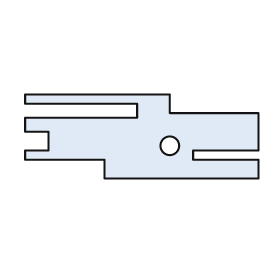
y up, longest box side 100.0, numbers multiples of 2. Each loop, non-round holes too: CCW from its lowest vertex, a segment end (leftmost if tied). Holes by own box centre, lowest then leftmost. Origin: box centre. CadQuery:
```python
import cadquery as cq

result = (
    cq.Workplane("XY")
    .moveTo(-16.0, -18.0)
    .lineTo(50.0, -18.0)
    .lineTo(50.0, -10.0)
    .lineTo(22.0, -10.0)
    .lineTo(22.0, -6.0)
    .lineTo(50.0, -6.0)
    .lineTo(50.0, 10.0)
    .lineTo(12.0, 10.0)
    .lineTo(12.0, 18.0)
    .lineTo(-50.0, 18.0)
    .lineTo(-50.0, 14.0)
    .lineTo(-2.0, 14.0)
    .lineTo(-2.0, 8.0)
    .lineTo(-50.0, 8.0)
    .lineTo(-50.0, 2.0)
    .lineTo(-40.0, 2.0)
    .lineTo(-40.0, -6.0)
    .lineTo(-50.0, -6.0)
    .lineTo(-50.0, -10.0)
    .lineTo(-16.0, -10.0)
    .close()
    .moveTo(12.0, -4.0)
    .circle(4.0)
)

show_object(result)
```